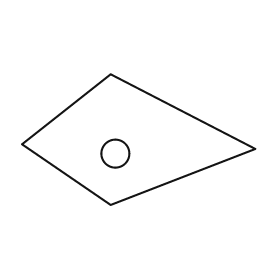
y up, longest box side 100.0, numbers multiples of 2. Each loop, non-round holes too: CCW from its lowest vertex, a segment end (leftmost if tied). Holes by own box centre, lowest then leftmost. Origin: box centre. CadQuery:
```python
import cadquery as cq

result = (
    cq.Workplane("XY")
    .moveTo(-12.0, -28.0)
    .lineTo(50.0, -4.0)
    .lineTo(-12.0, 28.0)
    .lineTo(-50.0, -2.0)
    .close()
    .moveTo(-10.0, -6.0)
    .circle(6.0)
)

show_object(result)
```